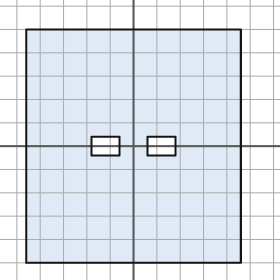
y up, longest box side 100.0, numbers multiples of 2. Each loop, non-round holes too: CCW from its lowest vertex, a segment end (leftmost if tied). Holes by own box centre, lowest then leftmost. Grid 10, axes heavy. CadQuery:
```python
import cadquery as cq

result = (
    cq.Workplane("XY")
    .moveTo(-46.0, -50.0)
    .lineTo(46.0, -50.0)
    .lineTo(46.0, 50.0)
    .lineTo(-46.0, 50.0)
    .close()
    .moveTo(-18.0, -4.0)
    .lineTo(-6.0, -4.0)
    .lineTo(-6.0, 4.0)
    .lineTo(-18.0, 4.0)
    .close()
    .moveTo(6.0, -4.0)
    .lineTo(18.0, -4.0)
    .lineTo(18.0, 4.0)
    .lineTo(6.0, 4.0)
    .close()
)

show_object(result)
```